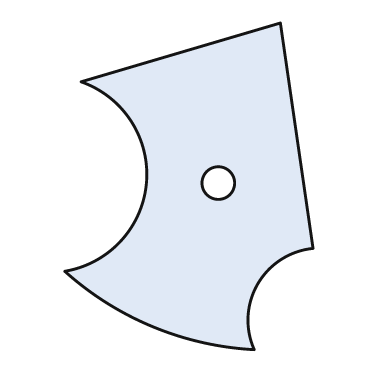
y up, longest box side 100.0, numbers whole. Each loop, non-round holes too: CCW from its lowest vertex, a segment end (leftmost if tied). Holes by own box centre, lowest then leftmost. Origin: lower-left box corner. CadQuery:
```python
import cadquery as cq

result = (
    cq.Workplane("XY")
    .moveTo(58.0, 0.0)
    .threePointArc((59.0, 20.0), (76.0, 31.0))
    .lineTo(66.0, 100.0)
    .lineTo(5.0, 82.0)
    .threePointArc((25.0, 51.0), (0.0, 24.0))
    .threePointArc((27.0, 7.0), (58.0, 0.0))
    .close()
    .moveTo(47.0, 51.0)
    .circle(5.0)
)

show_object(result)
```